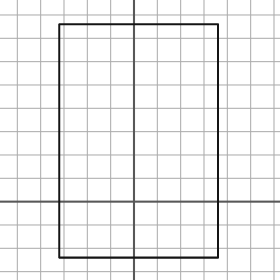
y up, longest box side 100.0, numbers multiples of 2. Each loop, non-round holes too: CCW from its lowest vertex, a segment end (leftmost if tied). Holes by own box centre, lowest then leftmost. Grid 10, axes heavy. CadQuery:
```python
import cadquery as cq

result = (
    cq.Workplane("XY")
    .moveTo(-32.0, -24.0)
    .lineTo(36.0, -24.0)
    .lineTo(36.0, 76.0)
    .lineTo(-32.0, 76.0)
    .close()
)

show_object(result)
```